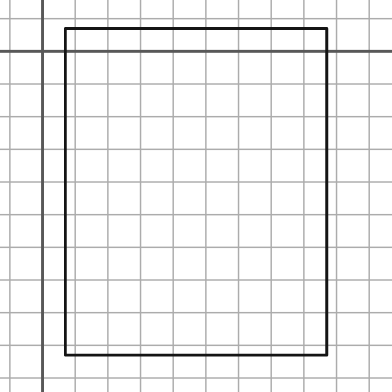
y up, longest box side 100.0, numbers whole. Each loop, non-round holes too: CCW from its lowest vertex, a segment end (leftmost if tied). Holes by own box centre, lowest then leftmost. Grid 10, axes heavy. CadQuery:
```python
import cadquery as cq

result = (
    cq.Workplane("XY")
    .moveTo(7.0, -93.0)
    .lineTo(87.0, -93.0)
    .lineTo(87.0, 7.0)
    .lineTo(7.0, 7.0)
    .close()
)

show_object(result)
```